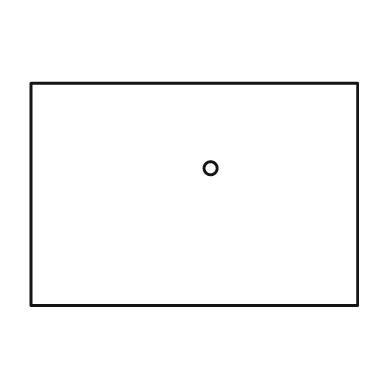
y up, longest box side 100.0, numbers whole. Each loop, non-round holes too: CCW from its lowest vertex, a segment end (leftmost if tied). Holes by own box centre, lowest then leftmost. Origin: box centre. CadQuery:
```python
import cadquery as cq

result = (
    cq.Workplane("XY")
    .moveTo(-50.0, -34.0)
    .lineTo(50.0, -34.0)
    .lineTo(50.0, 34.0)
    .lineTo(-50.0, 34.0)
    .close()
    .moveTo(5.0, 8.0)
    .circle(2.0)
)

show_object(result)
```